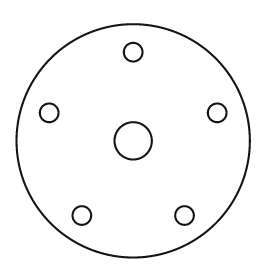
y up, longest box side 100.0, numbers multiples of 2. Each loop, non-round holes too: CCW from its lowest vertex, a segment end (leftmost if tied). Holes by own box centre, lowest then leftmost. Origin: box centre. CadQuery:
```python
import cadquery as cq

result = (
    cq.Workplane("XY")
    .moveTo(0.0, 0.0)
    .circle(50.0)
    .moveTo(-22.0, -32.0)
    .circle(4.0)
    .moveTo(22.0, -32.0)
    .circle(4.0)
    .moveTo(0.0, 0.0)
    .circle(8.0)
    .moveTo(-36.0, 12.0)
    .circle(4.0)
    .moveTo(36.0, 12.0)
    .circle(4.0)
    .moveTo(0.0, 38.0)
    .circle(4.0)
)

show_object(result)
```